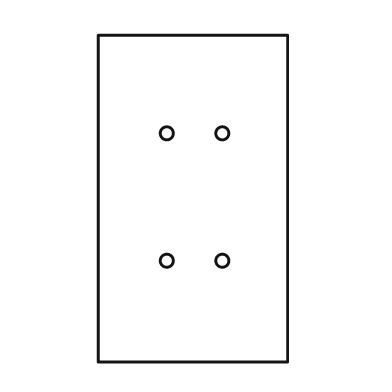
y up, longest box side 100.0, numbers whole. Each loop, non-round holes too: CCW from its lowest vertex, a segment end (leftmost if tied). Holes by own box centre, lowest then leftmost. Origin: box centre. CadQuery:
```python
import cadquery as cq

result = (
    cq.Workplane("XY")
    .moveTo(-29.0, -50.0)
    .lineTo(29.0, -50.0)
    .lineTo(29.0, 50.0)
    .lineTo(-29.0, 50.0)
    .close()
    .moveTo(-8.0, -19.0)
    .circle(2.0)
    .moveTo(9.0, -19.0)
    .circle(2.0)
    .moveTo(-8.0, 20.0)
    .circle(2.0)
    .moveTo(9.0, 20.0)
    .circle(2.0)
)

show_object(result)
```